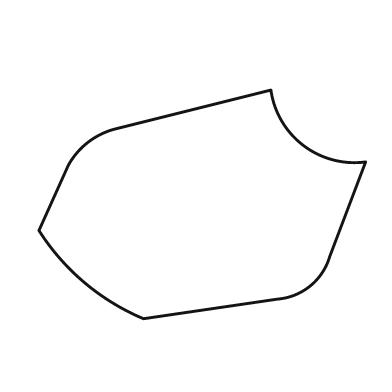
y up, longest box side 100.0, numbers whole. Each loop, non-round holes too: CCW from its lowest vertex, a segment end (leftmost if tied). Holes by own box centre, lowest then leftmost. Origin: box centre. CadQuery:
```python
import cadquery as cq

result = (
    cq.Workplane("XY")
    .moveTo(-18.0, -35.0)
    .lineTo(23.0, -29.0)
    .threePointArc((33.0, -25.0), (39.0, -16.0))
    .lineTo(50.0, 13.0)
    .threePointArc((31.0, 18.0), (21.0, 35.0))
    .lineTo(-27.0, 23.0)
    .threePointArc((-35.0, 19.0), (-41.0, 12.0))
    .lineTo(-50.0, -8.0)
    .threePointArc((-36.0, -24.0), (-18.0, -35.0))
    .close()
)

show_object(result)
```